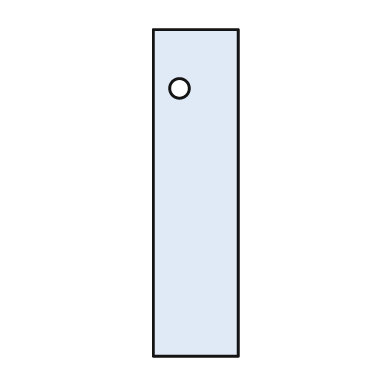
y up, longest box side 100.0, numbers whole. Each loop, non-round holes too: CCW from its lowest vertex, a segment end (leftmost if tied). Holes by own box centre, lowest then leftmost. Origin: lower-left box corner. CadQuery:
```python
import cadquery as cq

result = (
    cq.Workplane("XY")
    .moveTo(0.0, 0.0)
    .lineTo(26.0, 0.0)
    .lineTo(26.0, 100.0)
    .lineTo(0.0, 100.0)
    .close()
    .moveTo(8.0, 82.0)
    .circle(3.0)
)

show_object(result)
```